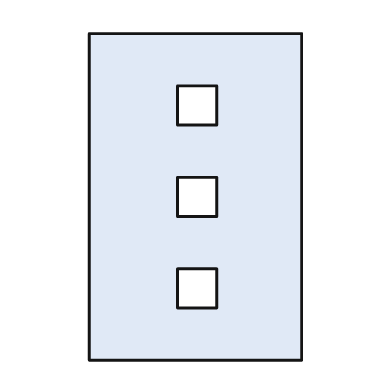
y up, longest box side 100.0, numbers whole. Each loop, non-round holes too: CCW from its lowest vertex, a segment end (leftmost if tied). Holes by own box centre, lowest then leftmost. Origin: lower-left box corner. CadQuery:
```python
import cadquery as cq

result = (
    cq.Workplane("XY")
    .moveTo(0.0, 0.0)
    .lineTo(65.0, 0.0)
    .lineTo(65.0, 100.0)
    .lineTo(0.0, 100.0)
    .close()
    .moveTo(27.0, 16.0)
    .lineTo(39.0, 16.0)
    .lineTo(39.0, 28.0)
    .lineTo(27.0, 28.0)
    .close()
    .moveTo(27.0, 44.0)
    .lineTo(39.0, 44.0)
    .lineTo(39.0, 56.0)
    .lineTo(27.0, 56.0)
    .close()
    .moveTo(27.0, 72.0)
    .lineTo(39.0, 72.0)
    .lineTo(39.0, 84.0)
    .lineTo(27.0, 84.0)
    .close()
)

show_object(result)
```